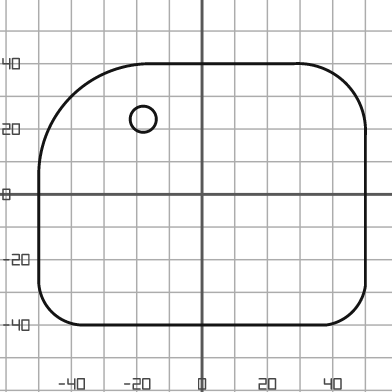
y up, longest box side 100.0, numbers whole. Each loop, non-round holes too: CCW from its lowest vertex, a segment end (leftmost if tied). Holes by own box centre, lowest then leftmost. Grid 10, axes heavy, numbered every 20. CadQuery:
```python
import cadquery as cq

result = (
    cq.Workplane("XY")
    .moveTo(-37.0, -40.0)
    .lineTo(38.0, -40.0)
    .threePointArc((46.0, -36.0), (50.0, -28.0))
    .lineTo(50.0, 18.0)
    .threePointArc((44.0, 34.0), (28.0, 40.0))
    .lineTo(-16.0, 40.0)
    .threePointArc((-40.0, 30.0), (-50.0, 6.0))
    .lineTo(-50.0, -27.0)
    .threePointArc((-46.0, -36.0), (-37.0, -40.0))
    .close()
    .moveTo(-18.0, 23.0)
    .circle(4.0)
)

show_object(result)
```